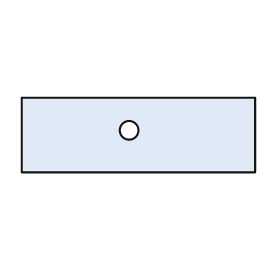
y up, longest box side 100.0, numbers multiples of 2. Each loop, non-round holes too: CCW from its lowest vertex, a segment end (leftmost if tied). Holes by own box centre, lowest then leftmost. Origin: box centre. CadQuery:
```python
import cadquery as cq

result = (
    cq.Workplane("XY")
    .moveTo(-50.0, -16.0)
    .lineTo(50.0, -16.0)
    .lineTo(50.0, 16.0)
    .lineTo(-50.0, 16.0)
    .close()
    .moveTo(-4.0, 2.0)
    .circle(4.0)
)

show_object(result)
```